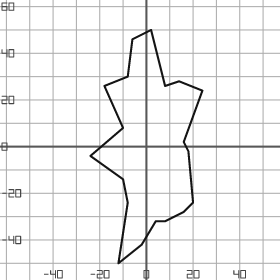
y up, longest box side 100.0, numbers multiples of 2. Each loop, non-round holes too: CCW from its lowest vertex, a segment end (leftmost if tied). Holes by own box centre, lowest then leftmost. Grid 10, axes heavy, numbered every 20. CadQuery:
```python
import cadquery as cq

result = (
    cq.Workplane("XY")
    .moveTo(-12.0, -50.0)
    .lineTo(-2.0, -42.0)
    .lineTo(4.0, -32.0)
    .lineTo(8.0, -32.0)
    .lineTo(16.0, -28.0)
    .lineTo(20.0, -24.0)
    .lineTo(18.0, -2.0)
    .lineTo(16.0, 2.0)
    .lineTo(24.0, 24.0)
    .lineTo(14.0, 28.0)
    .lineTo(8.0, 26.0)
    .lineTo(2.0, 50.0)
    .lineTo(-6.0, 46.0)
    .lineTo(-8.0, 30.0)
    .lineTo(-18.0, 26.0)
    .lineTo(-10.0, 8.0)
    .lineTo(-24.0, -4.0)
    .lineTo(-10.0, -14.0)
    .lineTo(-8.0, -24.0)
    .close()
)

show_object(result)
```